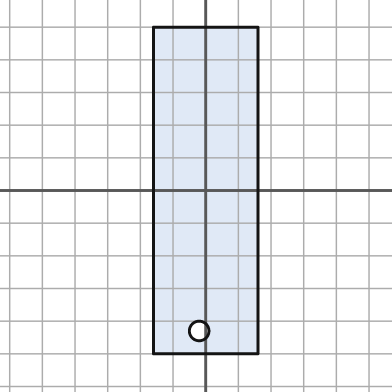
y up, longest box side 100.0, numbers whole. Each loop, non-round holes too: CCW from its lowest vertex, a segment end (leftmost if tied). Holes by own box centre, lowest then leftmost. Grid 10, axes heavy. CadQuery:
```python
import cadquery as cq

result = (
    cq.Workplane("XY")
    .moveTo(-16.0, -50.0)
    .lineTo(16.0, -50.0)
    .lineTo(16.0, 50.0)
    .lineTo(-16.0, 50.0)
    .close()
    .moveTo(-2.0, -43.0)
    .circle(3.0)
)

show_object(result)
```